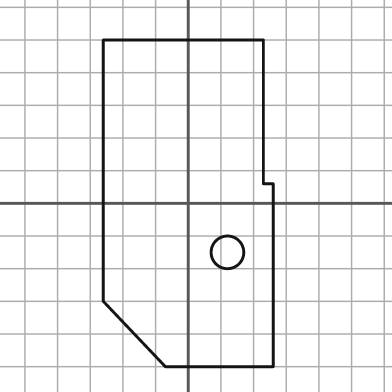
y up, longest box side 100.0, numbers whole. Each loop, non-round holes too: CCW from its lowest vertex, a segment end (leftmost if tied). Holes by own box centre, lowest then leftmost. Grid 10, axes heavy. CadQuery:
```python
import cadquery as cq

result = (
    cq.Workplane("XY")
    .moveTo(-7.0, -50.0)
    .lineTo(26.0, -50.0)
    .lineTo(26.0, 6.0)
    .lineTo(23.0, 6.0)
    .lineTo(23.0, 50.0)
    .lineTo(-26.0, 50.0)
    .lineTo(-26.0, -30.0)
    .close()
    .moveTo(12.0, -15.0)
    .circle(5.0)
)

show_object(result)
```